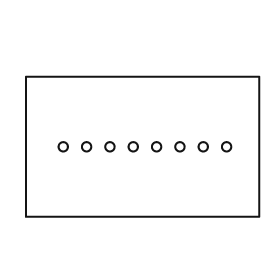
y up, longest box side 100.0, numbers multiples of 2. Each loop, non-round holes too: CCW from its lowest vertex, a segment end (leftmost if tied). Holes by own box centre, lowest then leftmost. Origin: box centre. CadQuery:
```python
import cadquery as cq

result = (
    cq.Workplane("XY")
    .moveTo(-50.0, -30.0)
    .lineTo(50.0, -30.0)
    .lineTo(50.0, 30.0)
    .lineTo(-50.0, 30.0)
    .close()
    .moveTo(-34.0, 0.0)
    .circle(2.0)
    .moveTo(-24.0, 0.0)
    .circle(2.0)
    .moveTo(-14.0, 0.0)
    .circle(2.0)
    .moveTo(-4.0, 0.0)
    .circle(2.0)
    .moveTo(6.0, 0.0)
    .circle(2.0)
    .moveTo(16.0, 0.0)
    .circle(2.0)
    .moveTo(26.0, 0.0)
    .circle(2.0)
    .moveTo(36.0, 0.0)
    .circle(2.0)
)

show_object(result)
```